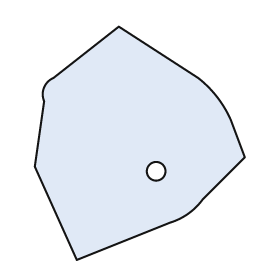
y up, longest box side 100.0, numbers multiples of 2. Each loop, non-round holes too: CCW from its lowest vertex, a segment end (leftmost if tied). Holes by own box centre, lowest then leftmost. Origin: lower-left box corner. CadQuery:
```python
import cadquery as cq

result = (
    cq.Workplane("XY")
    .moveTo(18.0, 0.0)
    .lineTo(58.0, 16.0)
    .threePointArc((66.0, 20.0), (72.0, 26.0))
    .lineTo(90.0, 44.0)
    .lineTo(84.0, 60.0)
    .threePointArc((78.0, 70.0), (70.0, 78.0))
    .lineTo(36.0, 100.0)
    .lineTo(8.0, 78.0)
    .threePointArc((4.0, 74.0), (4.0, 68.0))
    .lineTo(0.0, 40.0)
    .close()
    .moveTo(52.0, 38.0)
    .circle(4.0)
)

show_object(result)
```